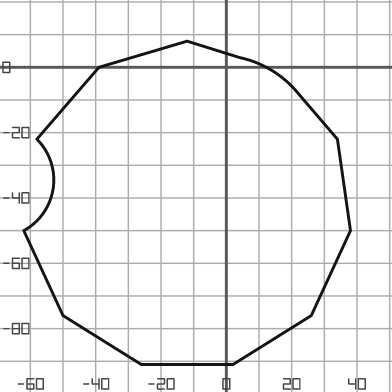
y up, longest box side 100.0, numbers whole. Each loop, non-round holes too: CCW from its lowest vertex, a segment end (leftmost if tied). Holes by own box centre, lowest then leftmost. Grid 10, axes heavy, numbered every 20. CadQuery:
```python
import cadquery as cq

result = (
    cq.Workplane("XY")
    .moveTo(-26.0, -91.0)
    .lineTo(2.0, -91.0)
    .lineTo(26.0, -76.0)
    .lineTo(38.0, -50.0)
    .lineTo(34.0, -22.0)
    .lineTo(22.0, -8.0)
    .threePointArc((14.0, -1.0), (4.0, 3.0))
    .lineTo(-12.0, 8.0)
    .lineTo(-39.0, 0.0)
    .lineTo(-58.0, -22.0)
    .threePointArc((-53.0, -37.0), (-62.0, -50.0))
    .lineTo(-50.0, -76.0)
    .close()
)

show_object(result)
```